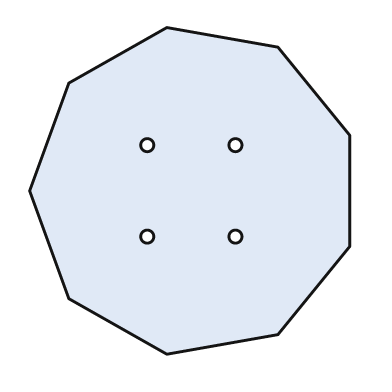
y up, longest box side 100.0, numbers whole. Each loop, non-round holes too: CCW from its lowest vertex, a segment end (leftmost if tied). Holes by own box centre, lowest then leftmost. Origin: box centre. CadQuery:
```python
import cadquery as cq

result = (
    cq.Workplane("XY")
    .moveTo(-7.0, -50.0)
    .lineTo(27.0, -44.0)
    .lineTo(49.0, -17.0)
    .lineTo(49.0, 17.0)
    .lineTo(27.0, 44.0)
    .lineTo(-7.0, 50.0)
    .lineTo(-37.0, 33.0)
    .lineTo(-49.0, 0.0)
    .lineTo(-37.0, -33.0)
    .close()
    .moveTo(-13.0, -14.0)
    .circle(2.0)
    .moveTo(14.0, -14.0)
    .circle(2.0)
    .moveTo(-13.0, 14.0)
    .circle(2.0)
    .moveTo(14.0, 14.0)
    .circle(2.0)
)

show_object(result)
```